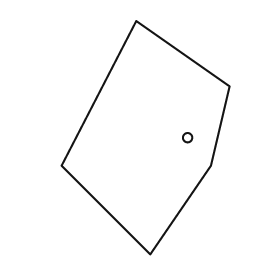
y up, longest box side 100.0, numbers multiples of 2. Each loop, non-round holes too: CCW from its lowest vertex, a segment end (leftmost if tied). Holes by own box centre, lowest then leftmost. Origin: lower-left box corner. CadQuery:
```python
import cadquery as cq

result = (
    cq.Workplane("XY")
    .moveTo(38.0, 0.0)
    .lineTo(64.0, 38.0)
    .lineTo(72.0, 72.0)
    .lineTo(32.0, 100.0)
    .lineTo(0.0, 38.0)
    .close()
    .moveTo(54.0, 50.0)
    .circle(2.0)
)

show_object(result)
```